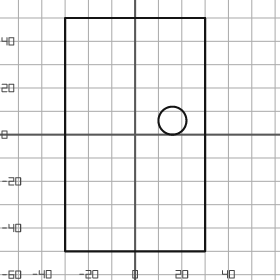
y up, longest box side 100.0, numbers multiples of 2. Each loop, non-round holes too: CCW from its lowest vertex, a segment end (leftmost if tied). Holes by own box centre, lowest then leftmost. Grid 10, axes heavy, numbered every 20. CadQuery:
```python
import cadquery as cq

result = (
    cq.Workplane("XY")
    .moveTo(-30.0, -50.0)
    .lineTo(30.0, -50.0)
    .lineTo(30.0, 50.0)
    .lineTo(-30.0, 50.0)
    .close()
    .moveTo(16.0, 6.0)
    .circle(6.0)
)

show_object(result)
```